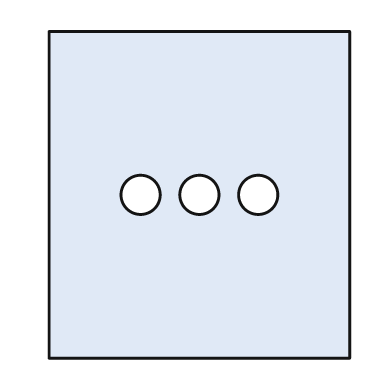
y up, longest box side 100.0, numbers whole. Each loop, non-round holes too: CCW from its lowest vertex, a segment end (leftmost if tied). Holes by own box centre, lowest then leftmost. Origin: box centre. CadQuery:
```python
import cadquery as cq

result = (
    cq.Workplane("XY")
    .moveTo(-46.0, -50.0)
    .lineTo(46.0, -50.0)
    .lineTo(46.0, 50.0)
    .lineTo(-46.0, 50.0)
    .close()
    .moveTo(-18.0, 0.0)
    .circle(6.0)
    .moveTo(0.0, 0.0)
    .circle(6.0)
    .moveTo(18.0, 0.0)
    .circle(6.0)
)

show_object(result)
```